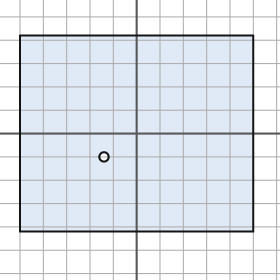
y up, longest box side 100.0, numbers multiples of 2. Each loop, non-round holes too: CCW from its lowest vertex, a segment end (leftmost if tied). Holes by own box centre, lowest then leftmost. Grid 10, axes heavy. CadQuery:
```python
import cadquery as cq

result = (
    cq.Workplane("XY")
    .moveTo(-50.0, -42.0)
    .lineTo(50.0, -42.0)
    .lineTo(50.0, 42.0)
    .lineTo(-50.0, 42.0)
    .close()
    .moveTo(-14.0, -10.0)
    .circle(2.0)
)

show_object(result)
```